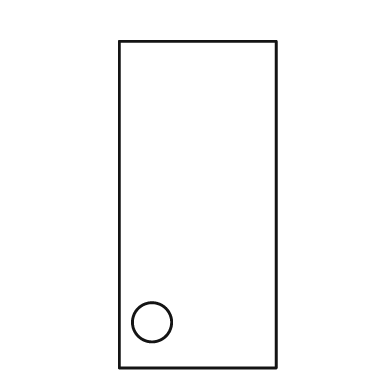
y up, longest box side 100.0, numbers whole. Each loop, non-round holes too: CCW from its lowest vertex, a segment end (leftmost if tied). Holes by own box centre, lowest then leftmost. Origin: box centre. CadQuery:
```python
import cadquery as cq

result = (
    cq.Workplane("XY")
    .moveTo(-24.0, -50.0)
    .lineTo(24.0, -50.0)
    .lineTo(24.0, 50.0)
    .lineTo(-24.0, 50.0)
    .close()
    .moveTo(-14.0, -36.0)
    .circle(6.0)
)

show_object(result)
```